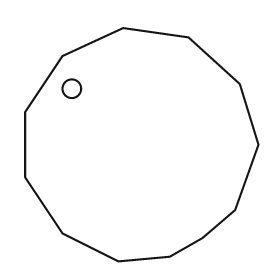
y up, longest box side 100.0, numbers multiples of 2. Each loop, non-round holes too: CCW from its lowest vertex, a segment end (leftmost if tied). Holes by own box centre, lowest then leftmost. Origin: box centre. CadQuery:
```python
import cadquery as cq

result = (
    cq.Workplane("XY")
    .moveTo(-10.0, -50.0)
    .lineTo(12.0, -48.0)
    .lineTo(26.0, -40.0)
    .lineTo(40.0, -28.0)
    .lineTo(50.0, 0.0)
    .lineTo(42.0, 26.0)
    .lineTo(20.0, 46.0)
    .lineTo(-8.0, 50.0)
    .lineTo(-34.0, 38.0)
    .lineTo(-50.0, 14.0)
    .lineTo(-50.0, -14.0)
    .lineTo(-34.0, -38.0)
    .close()
    .moveTo(-30.0, 24.0)
    .circle(4.0)
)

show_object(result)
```